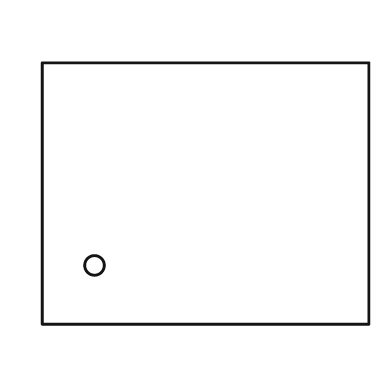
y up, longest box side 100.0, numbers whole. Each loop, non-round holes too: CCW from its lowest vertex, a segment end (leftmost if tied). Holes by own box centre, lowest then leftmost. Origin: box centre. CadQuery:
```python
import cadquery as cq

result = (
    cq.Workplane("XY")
    .moveTo(-50.0, -40.0)
    .lineTo(50.0, -40.0)
    .lineTo(50.0, 40.0)
    .lineTo(-50.0, 40.0)
    .close()
    .moveTo(-34.0, -22.0)
    .circle(3.0)
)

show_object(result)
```